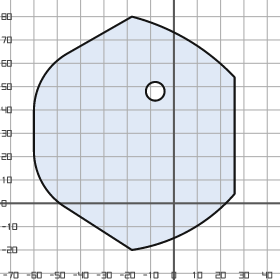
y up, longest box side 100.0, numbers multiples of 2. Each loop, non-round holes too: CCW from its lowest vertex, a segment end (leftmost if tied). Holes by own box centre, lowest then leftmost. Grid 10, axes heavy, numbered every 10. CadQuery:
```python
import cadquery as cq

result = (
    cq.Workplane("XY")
    .moveTo(-18.0, -20.0)
    .threePointArc((6.0, -12.0), (26.0, 4.0))
    .lineTo(26.0, 54.0)
    .threePointArc((6.0, 70.0), (-18.0, 80.0))
    .lineTo(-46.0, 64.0)
    .threePointArc((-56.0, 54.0), (-60.0, 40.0))
    .lineTo(-60.0, 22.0)
    .threePointArc((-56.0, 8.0), (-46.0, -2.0))
    .close()
    .moveTo(-8.0, 48.0)
    .circle(4.0)
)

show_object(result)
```